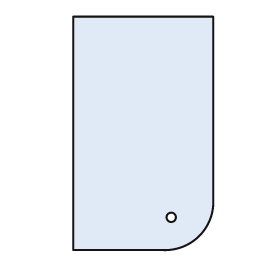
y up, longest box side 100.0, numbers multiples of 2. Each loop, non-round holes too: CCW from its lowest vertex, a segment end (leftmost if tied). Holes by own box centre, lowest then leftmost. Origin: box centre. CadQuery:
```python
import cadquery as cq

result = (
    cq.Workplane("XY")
    .moveTo(-30.0, -50.0)
    .lineTo(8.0, -50.0)
    .threePointArc((24.0, -44.0), (30.0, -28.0))
    .lineTo(30.0, 50.0)
    .lineTo(-30.0, 50.0)
    .close()
    .moveTo(12.0, -36.0)
    .circle(2.0)
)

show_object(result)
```